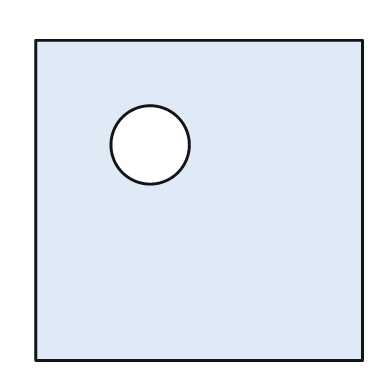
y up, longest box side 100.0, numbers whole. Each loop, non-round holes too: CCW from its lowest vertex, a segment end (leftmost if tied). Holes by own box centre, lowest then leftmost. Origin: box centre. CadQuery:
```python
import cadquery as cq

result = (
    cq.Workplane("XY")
    .moveTo(-50.0, -49.0)
    .lineTo(50.0, -49.0)
    .lineTo(50.0, 49.0)
    .lineTo(-50.0, 49.0)
    .close()
    .moveTo(-15.0, 17.0)
    .circle(12.0)
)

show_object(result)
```